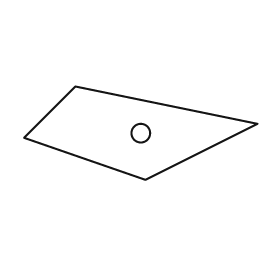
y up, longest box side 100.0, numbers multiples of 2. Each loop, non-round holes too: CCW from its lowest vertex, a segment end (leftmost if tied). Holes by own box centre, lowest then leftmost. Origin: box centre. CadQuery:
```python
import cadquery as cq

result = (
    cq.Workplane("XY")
    .moveTo(2.0, -20.0)
    .lineTo(50.0, 4.0)
    .lineTo(-28.0, 20.0)
    .lineTo(-50.0, -2.0)
    .close()
    .moveTo(0.0, 0.0)
    .circle(4.0)
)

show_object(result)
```